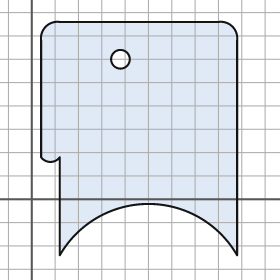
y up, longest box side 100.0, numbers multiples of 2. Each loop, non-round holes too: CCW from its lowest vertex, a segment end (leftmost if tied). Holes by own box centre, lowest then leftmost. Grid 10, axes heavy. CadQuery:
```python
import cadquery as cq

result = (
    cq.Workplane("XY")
    .moveTo(12.0, -24.0)
    .threePointArc((50.0, -2.0), (88.0, -24.0))
    .lineTo(88.0, 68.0)
    .threePointArc((86.0, 74.0), (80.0, 76.0))
    .lineTo(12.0, 76.0)
    .threePointArc((6.0, 74.0), (4.0, 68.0))
    .lineTo(4.0, 18.0)
    .threePointArc((8.0, 16.0), (12.0, 18.0))
    .close()
    .moveTo(38.0, 60.0)
    .circle(4.0)
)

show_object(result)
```